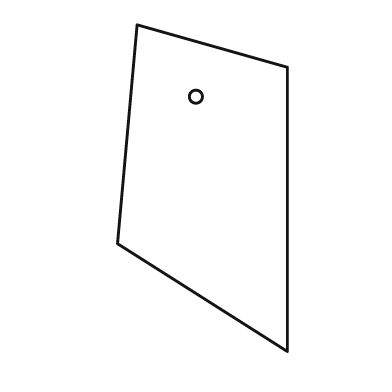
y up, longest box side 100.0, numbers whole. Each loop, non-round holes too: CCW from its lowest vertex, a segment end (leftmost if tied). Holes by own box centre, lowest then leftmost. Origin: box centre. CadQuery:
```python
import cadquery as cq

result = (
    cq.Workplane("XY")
    .moveTo(26.0, -50.0)
    .lineTo(26.0, 37.0)
    .lineTo(-20.0, 50.0)
    .lineTo(-26.0, -17.0)
    .close()
    .moveTo(-2.0, 28.0)
    .circle(2.0)
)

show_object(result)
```